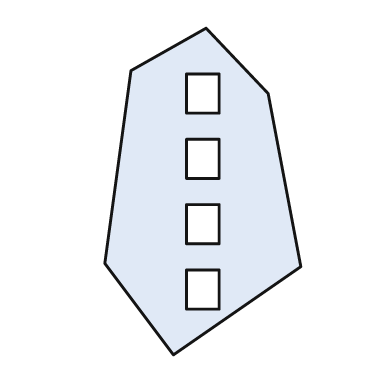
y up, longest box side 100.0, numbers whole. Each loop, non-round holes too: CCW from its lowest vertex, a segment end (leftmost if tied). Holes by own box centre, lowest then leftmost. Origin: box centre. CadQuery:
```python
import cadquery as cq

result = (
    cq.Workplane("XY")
    .moveTo(-9.0, -50.0)
    .lineTo(30.0, -23.0)
    .lineTo(20.0, 30.0)
    .lineTo(1.0, 50.0)
    .lineTo(-22.0, 37.0)
    .lineTo(-30.0, -22.0)
    .close()
    .moveTo(-5.0, -36.0)
    .lineTo(5.0, -36.0)
    .lineTo(5.0, -24.0)
    .lineTo(-5.0, -24.0)
    .close()
    .moveTo(-5.0, -16.0)
    .lineTo(5.0, -16.0)
    .lineTo(5.0, -4.0)
    .lineTo(-5.0, -4.0)
    .close()
    .moveTo(-5.0, 4.0)
    .lineTo(5.0, 4.0)
    .lineTo(5.0, 16.0)
    .lineTo(-5.0, 16.0)
    .close()
    .moveTo(-5.0, 24.0)
    .lineTo(5.0, 24.0)
    .lineTo(5.0, 36.0)
    .lineTo(-5.0, 36.0)
    .close()
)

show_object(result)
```